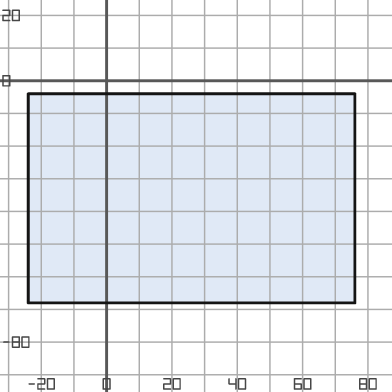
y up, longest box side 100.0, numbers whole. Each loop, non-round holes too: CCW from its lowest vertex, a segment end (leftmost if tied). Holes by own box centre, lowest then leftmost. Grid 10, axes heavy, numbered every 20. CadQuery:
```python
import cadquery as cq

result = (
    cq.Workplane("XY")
    .moveTo(-24.0, -68.0)
    .lineTo(76.0, -68.0)
    .lineTo(76.0, -4.0)
    .lineTo(-24.0, -4.0)
    .close()
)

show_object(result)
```